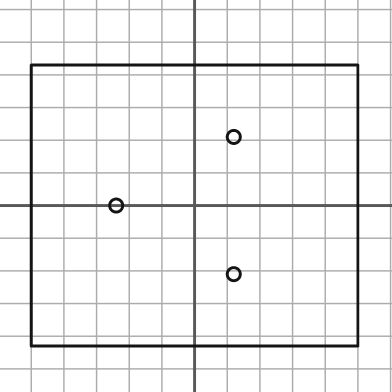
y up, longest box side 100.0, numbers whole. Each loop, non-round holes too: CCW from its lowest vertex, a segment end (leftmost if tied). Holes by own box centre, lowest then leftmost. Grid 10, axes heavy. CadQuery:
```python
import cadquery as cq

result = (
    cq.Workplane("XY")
    .moveTo(-50.0, -43.0)
    .lineTo(50.0, -43.0)
    .lineTo(50.0, 43.0)
    .lineTo(-50.0, 43.0)
    .close()
    .moveTo(12.0, -21.0)
    .circle(2.0)
    .moveTo(-24.0, 0.0)
    .circle(2.0)
    .moveTo(12.0, 21.0)
    .circle(2.0)
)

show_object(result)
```